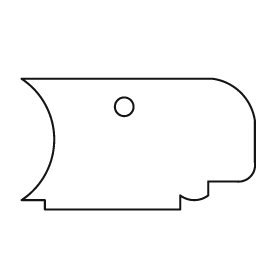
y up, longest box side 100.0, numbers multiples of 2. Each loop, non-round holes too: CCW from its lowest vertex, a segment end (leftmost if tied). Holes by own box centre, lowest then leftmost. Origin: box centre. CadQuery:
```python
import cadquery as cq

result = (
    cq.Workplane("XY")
    .moveTo(-40.0, -28.0)
    .lineTo(18.0, -28.0)
    .lineTo(18.0, -22.0)
    .threePointArc((24.0, -24.0), (30.0, -22.0))
    .lineTo(30.0, -16.0)
    .lineTo(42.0, -16.0)
    .threePointArc((48.0, -14.0), (50.0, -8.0))
    .lineTo(50.0, 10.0)
    .threePointArc((44.0, 22.0), (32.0, 28.0))
    .lineTo(-50.0, 28.0)
    .threePointArc((-36.0, 2.0), (-50.0, -24.0))
    .lineTo(-40.0, -24.0)
    .close()
    .moveTo(-6.0, 16.0)
    .circle(4.0)
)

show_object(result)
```